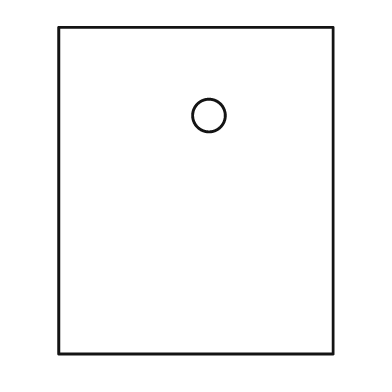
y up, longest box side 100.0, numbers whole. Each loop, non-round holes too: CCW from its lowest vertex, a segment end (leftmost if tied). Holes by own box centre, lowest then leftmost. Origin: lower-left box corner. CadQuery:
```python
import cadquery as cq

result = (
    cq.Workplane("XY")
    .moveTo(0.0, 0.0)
    .lineTo(84.0, 0.0)
    .lineTo(84.0, 100.0)
    .lineTo(0.0, 100.0)
    .close()
    .moveTo(46.0, 73.0)
    .circle(5.0)
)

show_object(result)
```